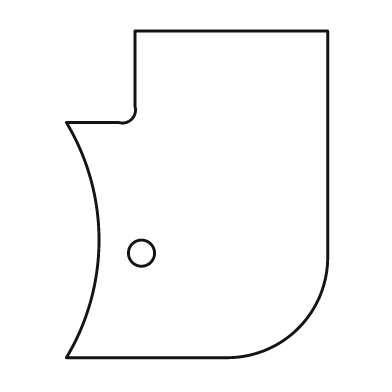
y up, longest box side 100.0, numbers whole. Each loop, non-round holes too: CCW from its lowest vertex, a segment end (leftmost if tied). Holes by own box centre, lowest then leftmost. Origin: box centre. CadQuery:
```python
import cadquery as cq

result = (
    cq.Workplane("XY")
    .moveTo(-40.0, -50.0)
    .lineTo(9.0, -50.0)
    .threePointArc((31.0, -41.0), (40.0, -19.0))
    .lineTo(40.0, 50.0)
    .lineTo(-19.0, 50.0)
    .lineTo(-19.0, 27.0)
    .threePointArc((-20.0, 23.0), (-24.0, 22.0))
    .lineTo(-40.0, 22.0)
    .threePointArc((-30.0, -14.0), (-40.0, -50.0))
    .close()
    .moveTo(-17.0, -18.0)
    .circle(4.0)
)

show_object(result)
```